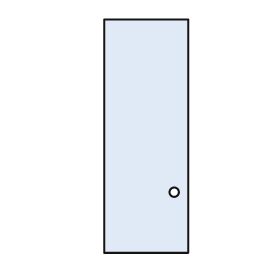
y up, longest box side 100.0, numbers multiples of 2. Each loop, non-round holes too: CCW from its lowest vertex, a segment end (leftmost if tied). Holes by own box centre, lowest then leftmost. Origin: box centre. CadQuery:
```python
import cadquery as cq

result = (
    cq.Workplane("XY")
    .moveTo(-18.0, -50.0)
    .lineTo(18.0, -50.0)
    .lineTo(18.0, 50.0)
    .lineTo(-18.0, 50.0)
    .close()
    .moveTo(12.0, -24.0)
    .circle(2.0)
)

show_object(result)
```